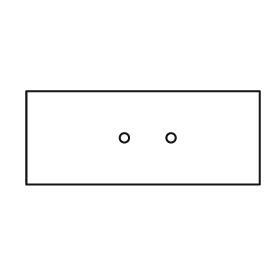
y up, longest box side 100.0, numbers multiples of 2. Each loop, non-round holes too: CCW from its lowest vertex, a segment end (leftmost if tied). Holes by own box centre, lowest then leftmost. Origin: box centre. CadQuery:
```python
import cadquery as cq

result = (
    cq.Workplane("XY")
    .moveTo(-50.0, -20.0)
    .lineTo(50.0, -20.0)
    .lineTo(50.0, 20.0)
    .lineTo(-50.0, 20.0)
    .close()
    .moveTo(-8.0, 0.0)
    .circle(2.0)
    .moveTo(12.0, 0.0)
    .circle(2.0)
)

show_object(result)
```